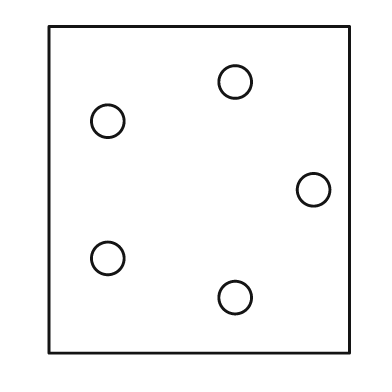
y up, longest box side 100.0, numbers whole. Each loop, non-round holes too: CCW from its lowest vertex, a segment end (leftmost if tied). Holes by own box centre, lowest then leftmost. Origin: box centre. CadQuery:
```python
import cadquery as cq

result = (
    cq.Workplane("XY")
    .moveTo(-46.0, -50.0)
    .lineTo(46.0, -50.0)
    .lineTo(46.0, 50.0)
    .lineTo(-46.0, 50.0)
    .close()
    .moveTo(11.0, -33.0)
    .circle(5.0)
    .moveTo(-28.0, -21.0)
    .circle(5.0)
    .moveTo(35.0, 0.0)
    .circle(5.0)
    .moveTo(-28.0, 21.0)
    .circle(5.0)
    .moveTo(11.0, 33.0)
    .circle(5.0)
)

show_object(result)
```